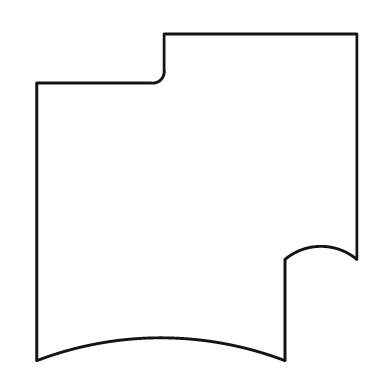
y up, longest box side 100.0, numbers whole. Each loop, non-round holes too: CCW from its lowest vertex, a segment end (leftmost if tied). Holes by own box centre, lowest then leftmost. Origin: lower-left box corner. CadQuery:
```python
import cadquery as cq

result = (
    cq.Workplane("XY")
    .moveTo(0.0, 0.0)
    .threePointArc((38.0, 7.0), (76.0, 0.0))
    .lineTo(76.0, 31.0)
    .threePointArc((87.0, 35.0), (98.0, 31.0))
    .lineTo(98.0, 100.0)
    .lineTo(39.0, 100.0)
    .lineTo(39.0, 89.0)
    .threePointArc((38.0, 86.0), (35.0, 85.0))
    .lineTo(0.0, 85.0)
    .close()
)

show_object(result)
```